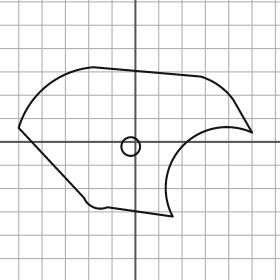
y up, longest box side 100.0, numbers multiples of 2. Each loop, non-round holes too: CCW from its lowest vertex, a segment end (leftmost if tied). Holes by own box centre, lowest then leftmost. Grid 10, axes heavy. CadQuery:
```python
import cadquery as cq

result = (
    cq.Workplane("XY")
    .moveTo(16.0, -32.0)
    .threePointArc((20.0, -2.0), (50.0, 4.0))
    .lineTo(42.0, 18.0)
    .threePointArc((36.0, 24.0), (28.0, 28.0))
    .lineTo(-18.0, 32.0)
    .threePointArc((-38.0, 24.0), (-50.0, 6.0))
    .lineTo(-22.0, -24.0)
    .threePointArc((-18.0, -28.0), (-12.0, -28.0))
    .close()
    .moveTo(-2.0, -2.0)
    .circle(4.0)
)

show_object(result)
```